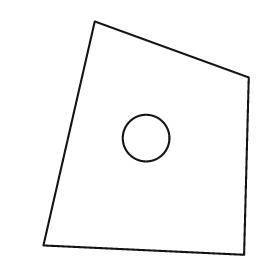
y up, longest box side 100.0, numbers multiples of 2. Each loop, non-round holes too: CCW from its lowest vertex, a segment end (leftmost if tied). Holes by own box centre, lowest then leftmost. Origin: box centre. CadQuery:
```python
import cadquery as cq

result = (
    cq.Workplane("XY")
    .moveTo(42.0, -50.0)
    .lineTo(44.0, 26.0)
    .lineTo(-22.0, 50.0)
    .lineTo(-44.0, -46.0)
    .close()
    .moveTo(0.0, 0.0)
    .circle(10.0)
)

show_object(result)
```